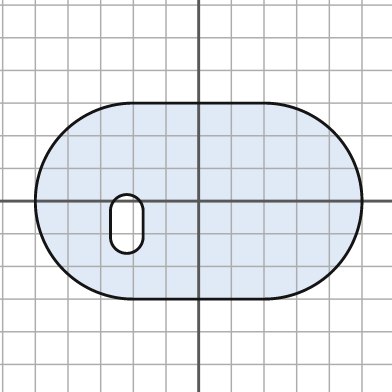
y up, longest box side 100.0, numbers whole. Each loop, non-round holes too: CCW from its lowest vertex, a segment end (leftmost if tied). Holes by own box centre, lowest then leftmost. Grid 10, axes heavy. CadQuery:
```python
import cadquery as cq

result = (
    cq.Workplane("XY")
    .moveTo(-20.0, -30.0)
    .lineTo(20.0, -30.0)
    .threePointArc((50.0, 0.0), (20.0, 30.0))
    .lineTo(-20.0, 30.0)
    .threePointArc((-50.0, 0.0), (-20.0, -30.0))
    .close()
    .moveTo(-27.0, -11.0)
    .threePointArc((-22.0, -16.0), (-17.0, -11.0))
    .lineTo(-17.0, -3.0)
    .threePointArc((-22.0, 2.0), (-27.0, -3.0))
    .close()
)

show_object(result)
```